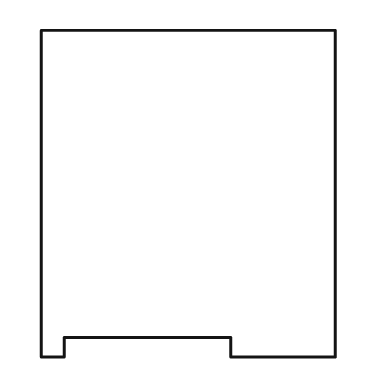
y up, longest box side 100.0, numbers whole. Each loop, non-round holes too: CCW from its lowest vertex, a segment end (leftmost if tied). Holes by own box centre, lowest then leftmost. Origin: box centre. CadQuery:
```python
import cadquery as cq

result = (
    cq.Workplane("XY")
    .moveTo(-45.0, -50.0)
    .lineTo(-38.0, -50.0)
    .lineTo(-38.0, -44.0)
    .lineTo(13.0, -44.0)
    .lineTo(13.0, -50.0)
    .lineTo(45.0, -50.0)
    .lineTo(45.0, 50.0)
    .lineTo(-45.0, 50.0)
    .close()
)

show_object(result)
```